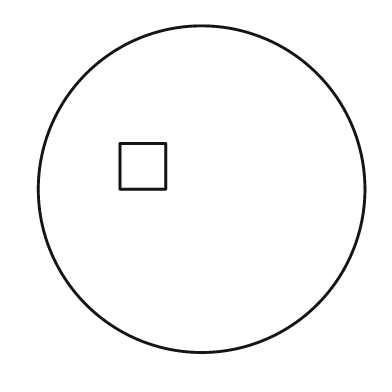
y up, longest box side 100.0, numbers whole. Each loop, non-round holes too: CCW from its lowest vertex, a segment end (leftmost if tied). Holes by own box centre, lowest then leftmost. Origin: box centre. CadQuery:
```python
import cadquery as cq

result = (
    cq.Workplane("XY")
    .moveTo(0.0, 0.0)
    .circle(50.0)
    .moveTo(-25.0, 0.0)
    .lineTo(-11.0, 0.0)
    .lineTo(-11.0, 14.0)
    .lineTo(-25.0, 14.0)
    .close()
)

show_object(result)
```